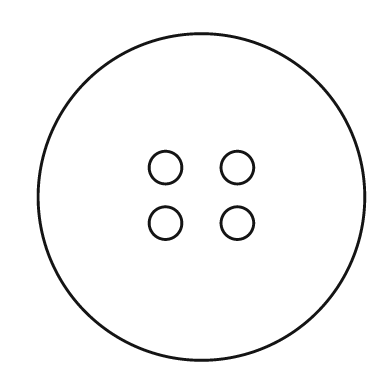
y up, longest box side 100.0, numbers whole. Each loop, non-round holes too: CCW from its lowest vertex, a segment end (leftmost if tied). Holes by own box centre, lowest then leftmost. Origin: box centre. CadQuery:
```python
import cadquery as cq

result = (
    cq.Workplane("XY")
    .moveTo(0.0, 0.0)
    .circle(50.0)
    .moveTo(-11.0, -8.0)
    .circle(5.0)
    .moveTo(11.0, -8.0)
    .circle(5.0)
    .moveTo(-11.0, 9.0)
    .circle(5.0)
    .moveTo(11.0, 9.0)
    .circle(5.0)
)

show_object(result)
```